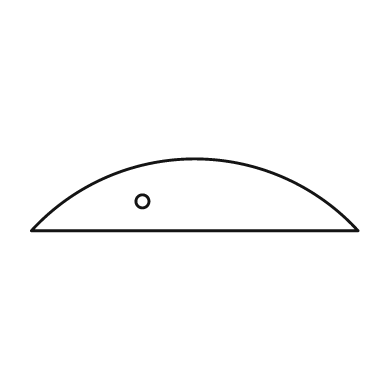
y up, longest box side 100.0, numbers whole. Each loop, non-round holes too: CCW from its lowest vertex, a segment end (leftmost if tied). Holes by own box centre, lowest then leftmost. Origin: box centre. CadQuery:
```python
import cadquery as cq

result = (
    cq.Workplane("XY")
    .moveTo(-50.0, -11.0)
    .lineTo(50.0, -11.0)
    .threePointArc((0.0, 11.0), (-50.0, -11.0))
    .close()
    .moveTo(-16.0, -2.0)
    .circle(2.0)
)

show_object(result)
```